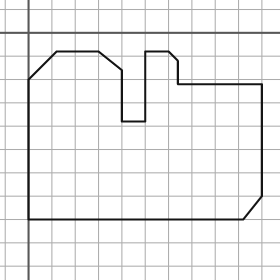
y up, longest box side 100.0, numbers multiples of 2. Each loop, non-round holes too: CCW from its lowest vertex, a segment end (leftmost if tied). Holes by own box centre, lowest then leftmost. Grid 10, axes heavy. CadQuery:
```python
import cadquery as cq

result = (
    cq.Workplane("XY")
    .moveTo(0.0, -80.0)
    .lineTo(92.0, -80.0)
    .lineTo(100.0, -70.0)
    .lineTo(100.0, -22.0)
    .lineTo(64.0, -22.0)
    .lineTo(64.0, -12.0)
    .lineTo(60.0, -8.0)
    .lineTo(50.0, -8.0)
    .lineTo(50.0, -38.0)
    .lineTo(40.0, -38.0)
    .lineTo(40.0, -16.0)
    .lineTo(30.0, -8.0)
    .lineTo(12.0, -8.0)
    .lineTo(0.0, -20.0)
    .close()
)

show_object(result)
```